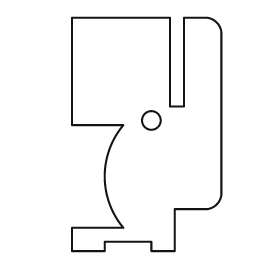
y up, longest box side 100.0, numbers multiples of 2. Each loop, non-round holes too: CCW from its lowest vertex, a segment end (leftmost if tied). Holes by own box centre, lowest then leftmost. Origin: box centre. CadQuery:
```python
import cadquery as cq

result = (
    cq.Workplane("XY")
    .moveTo(-32.0, -50.0)
    .lineTo(-18.0, -50.0)
    .lineTo(-18.0, -46.0)
    .lineTo(2.0, -46.0)
    .lineTo(2.0, -50.0)
    .lineTo(12.0, -50.0)
    .lineTo(12.0, -32.0)
    .lineTo(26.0, -32.0)
    .threePointArc((30.0, -30.0), (32.0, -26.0))
    .lineTo(32.0, 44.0)
    .threePointArc((30.0, 48.0), (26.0, 50.0))
    .lineTo(16.0, 50.0)
    .lineTo(16.0, 12.0)
    .lineTo(10.0, 12.0)
    .lineTo(10.0, 50.0)
    .lineTo(-32.0, 50.0)
    .lineTo(-32.0, 4.0)
    .lineTo(-10.0, 4.0)
    .threePointArc((-18.0, -18.0), (-10.0, -40.0))
    .lineTo(-32.0, -40.0)
    .close()
    .moveTo(2.0, 6.0)
    .circle(4.0)
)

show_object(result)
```